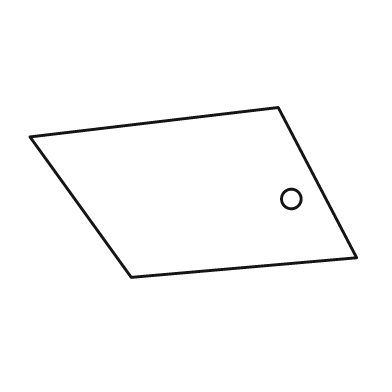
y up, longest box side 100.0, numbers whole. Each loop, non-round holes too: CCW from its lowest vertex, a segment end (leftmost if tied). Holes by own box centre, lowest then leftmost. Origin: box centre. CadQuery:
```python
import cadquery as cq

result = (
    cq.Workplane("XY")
    .moveTo(-19.0, -26.0)
    .lineTo(50.0, -20.0)
    .lineTo(26.0, 26.0)
    .lineTo(-50.0, 17.0)
    .close()
    .moveTo(30.0, -2.0)
    .circle(3.0)
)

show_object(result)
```